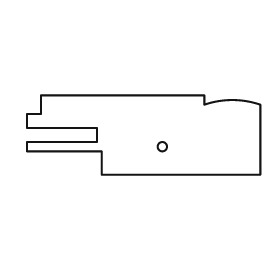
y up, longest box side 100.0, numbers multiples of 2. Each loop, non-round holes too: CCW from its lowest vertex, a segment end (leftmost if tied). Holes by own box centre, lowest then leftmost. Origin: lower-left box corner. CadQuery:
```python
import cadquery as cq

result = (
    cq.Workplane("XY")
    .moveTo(32.0, 0.0)
    .lineTo(100.0, 0.0)
    .lineTo(100.0, 30.0)
    .threePointArc((88.0, 32.0), (76.0, 30.0))
    .lineTo(76.0, 34.0)
    .lineTo(6.0, 34.0)
    .lineTo(6.0, 26.0)
    .lineTo(0.0, 26.0)
    .lineTo(0.0, 20.0)
    .lineTo(30.0, 20.0)
    .lineTo(30.0, 14.0)
    .lineTo(0.0, 14.0)
    .lineTo(0.0, 10.0)
    .lineTo(32.0, 10.0)
    .close()
    .moveTo(58.0, 12.0)
    .circle(2.0)
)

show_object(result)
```